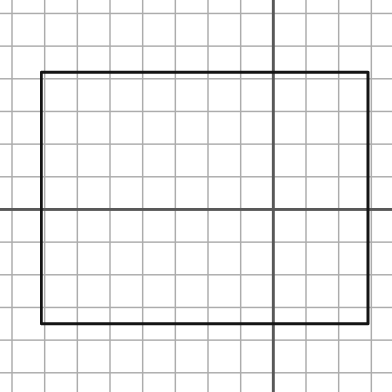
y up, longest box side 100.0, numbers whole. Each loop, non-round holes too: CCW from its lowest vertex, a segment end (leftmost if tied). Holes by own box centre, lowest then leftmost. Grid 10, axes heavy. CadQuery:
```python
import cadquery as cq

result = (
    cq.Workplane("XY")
    .moveTo(-71.0, -35.0)
    .lineTo(29.0, -35.0)
    .lineTo(29.0, 42.0)
    .lineTo(-71.0, 42.0)
    .close()
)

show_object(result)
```